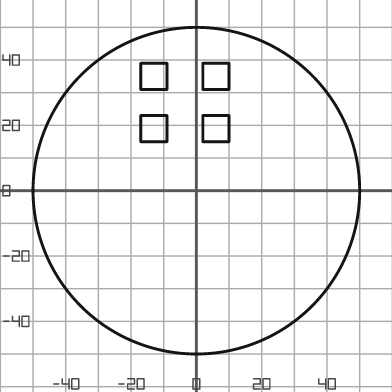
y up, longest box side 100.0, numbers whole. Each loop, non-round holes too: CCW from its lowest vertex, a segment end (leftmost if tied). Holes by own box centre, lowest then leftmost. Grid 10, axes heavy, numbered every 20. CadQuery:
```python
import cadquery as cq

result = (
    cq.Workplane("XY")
    .moveTo(0.0, 0.0)
    .circle(50.0)
    .moveTo(-17.0, 15.0)
    .lineTo(-9.0, 15.0)
    .lineTo(-9.0, 23.0)
    .lineTo(-17.0, 23.0)
    .close()
    .moveTo(2.0, 15.0)
    .lineTo(10.0, 15.0)
    .lineTo(10.0, 23.0)
    .lineTo(2.0, 23.0)
    .close()
    .moveTo(-17.0, 31.0)
    .lineTo(-9.0, 31.0)
    .lineTo(-9.0, 39.0)
    .lineTo(-17.0, 39.0)
    .close()
    .moveTo(2.0, 31.0)
    .lineTo(10.0, 31.0)
    .lineTo(10.0, 39.0)
    .lineTo(2.0, 39.0)
    .close()
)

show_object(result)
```